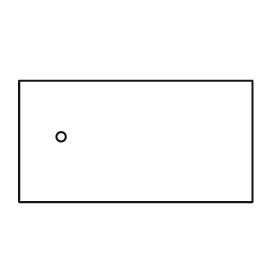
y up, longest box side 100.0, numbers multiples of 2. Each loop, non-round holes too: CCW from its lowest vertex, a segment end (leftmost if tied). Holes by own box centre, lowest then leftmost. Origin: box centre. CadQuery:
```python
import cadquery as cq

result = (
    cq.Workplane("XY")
    .moveTo(-50.0, -26.0)
    .lineTo(50.0, -26.0)
    .lineTo(50.0, 26.0)
    .lineTo(-50.0, 26.0)
    .close()
    .moveTo(-32.0, 2.0)
    .circle(2.0)
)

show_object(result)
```